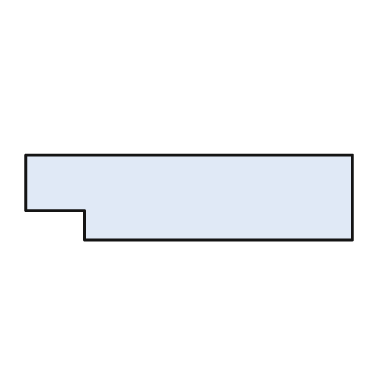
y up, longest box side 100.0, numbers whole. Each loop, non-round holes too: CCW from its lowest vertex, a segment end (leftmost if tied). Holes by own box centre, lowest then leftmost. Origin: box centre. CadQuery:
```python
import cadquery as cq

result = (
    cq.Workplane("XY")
    .moveTo(-32.0, -13.0)
    .lineTo(50.0, -13.0)
    .lineTo(50.0, 13.0)
    .lineTo(-50.0, 13.0)
    .lineTo(-50.0, -4.0)
    .lineTo(-32.0, -4.0)
    .close()
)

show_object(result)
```